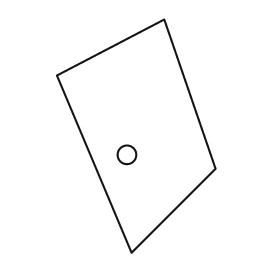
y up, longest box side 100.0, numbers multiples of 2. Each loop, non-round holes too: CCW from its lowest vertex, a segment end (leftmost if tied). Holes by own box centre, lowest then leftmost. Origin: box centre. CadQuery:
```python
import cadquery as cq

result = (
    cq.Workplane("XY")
    .moveTo(-2.0, -50.0)
    .lineTo(34.0, -14.0)
    .lineTo(12.0, 50.0)
    .lineTo(-34.0, 26.0)
    .close()
    .moveTo(-4.0, -8.0)
    .circle(4.0)
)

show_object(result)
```